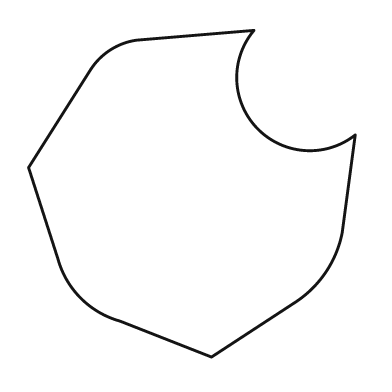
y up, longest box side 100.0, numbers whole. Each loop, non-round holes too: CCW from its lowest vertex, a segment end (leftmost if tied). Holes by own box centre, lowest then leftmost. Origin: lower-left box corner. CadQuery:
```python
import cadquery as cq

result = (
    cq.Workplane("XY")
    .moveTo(56.0, 0.0)
    .lineTo(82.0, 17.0)
    .threePointArc((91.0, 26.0), (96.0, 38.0))
    .lineTo(100.0, 68.0)
    .threePointArc((70.0, 70.0), (69.0, 100.0))
    .lineTo(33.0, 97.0)
    .threePointArc((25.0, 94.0), (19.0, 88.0))
    .lineTo(0.0, 58.0)
    .lineTo(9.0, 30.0)
    .threePointArc((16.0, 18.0), (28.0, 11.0))
    .close()
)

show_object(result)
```